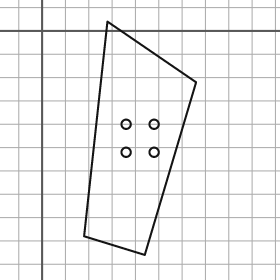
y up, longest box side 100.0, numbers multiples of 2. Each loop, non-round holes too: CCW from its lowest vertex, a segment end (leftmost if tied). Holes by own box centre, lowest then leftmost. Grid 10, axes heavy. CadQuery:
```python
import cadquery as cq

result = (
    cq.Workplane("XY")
    .moveTo(44.0, -96.0)
    .lineTo(66.0, -22.0)
    .lineTo(28.0, 4.0)
    .lineTo(18.0, -88.0)
    .close()
    .moveTo(36.0, -52.0)
    .circle(2.0)
    .moveTo(48.0, -52.0)
    .circle(2.0)
    .moveTo(36.0, -40.0)
    .circle(2.0)
    .moveTo(48.0, -40.0)
    .circle(2.0)
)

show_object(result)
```